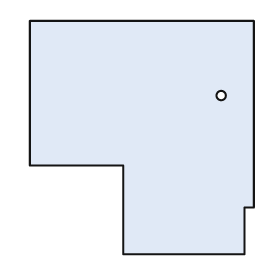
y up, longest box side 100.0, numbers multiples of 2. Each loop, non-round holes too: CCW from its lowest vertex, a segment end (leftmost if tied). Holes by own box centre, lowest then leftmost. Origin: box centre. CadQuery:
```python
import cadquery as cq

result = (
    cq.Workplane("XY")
    .moveTo(-8.0, -50.0)
    .lineTo(44.0, -50.0)
    .lineTo(44.0, -30.0)
    .lineTo(48.0, -30.0)
    .lineTo(48.0, 50.0)
    .lineTo(-48.0, 50.0)
    .lineTo(-48.0, -12.0)
    .lineTo(-8.0, -12.0)
    .close()
    .moveTo(34.0, 18.0)
    .circle(2.0)
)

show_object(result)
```